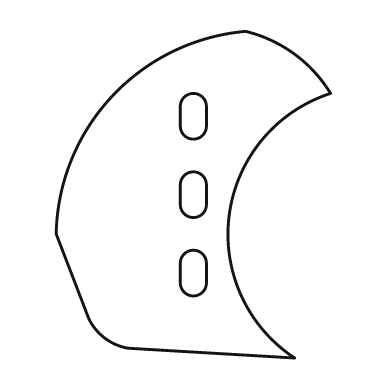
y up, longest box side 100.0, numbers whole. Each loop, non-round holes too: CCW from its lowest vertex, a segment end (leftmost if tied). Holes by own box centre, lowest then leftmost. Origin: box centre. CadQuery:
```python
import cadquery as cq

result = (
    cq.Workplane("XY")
    .moveTo(31.0, -50.0)
    .threePointArc((11.0, -6.0), (42.0, 31.0))
    .threePointArc((31.0, 43.0), (16.0, 50.0))
    .threePointArc((-25.0, 30.0), (-42.0, -12.0))
    .lineTo(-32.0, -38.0)
    .threePointArc((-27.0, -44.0), (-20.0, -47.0))
    .close()
    .moveTo(-4.0, -27.0)
    .threePointArc((0.0, -31.0), (4.0, -27.0))
    .lineTo(4.0, -21.0)
    .threePointArc((0.0, -17.0), (-4.0, -21.0))
    .close()
    .moveTo(-4.0, -3.0)
    .threePointArc((0.0, -7.0), (4.0, -3.0))
    .lineTo(4.0, 3.0)
    .threePointArc((0.0, 7.0), (-4.0, 3.0))
    .close()
    .moveTo(-4.0, 21.0)
    .threePointArc((0.0, 17.0), (4.0, 21.0))
    .lineTo(4.0, 27.0)
    .threePointArc((0.0, 31.0), (-4.0, 27.0))
    .close()
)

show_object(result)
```